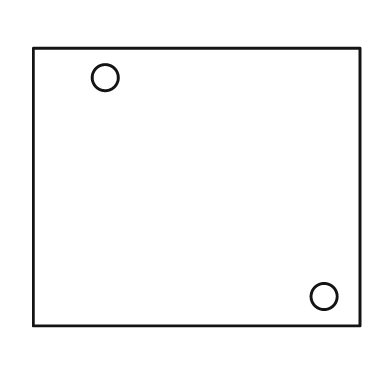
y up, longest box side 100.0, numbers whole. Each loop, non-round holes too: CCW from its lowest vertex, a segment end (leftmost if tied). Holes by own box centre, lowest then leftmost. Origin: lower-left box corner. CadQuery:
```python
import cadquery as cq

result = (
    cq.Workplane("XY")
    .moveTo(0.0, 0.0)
    .lineTo(100.0, 0.0)
    .lineTo(100.0, 85.0)
    .lineTo(0.0, 85.0)
    .close()
    .moveTo(89.0, 9.0)
    .circle(4.0)
    .moveTo(22.0, 76.0)
    .circle(4.0)
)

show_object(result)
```